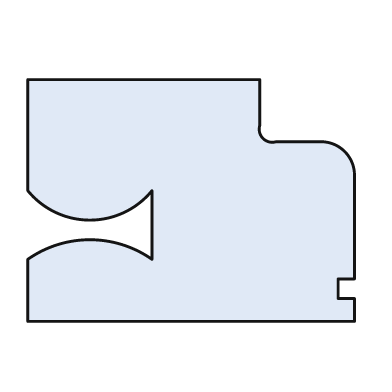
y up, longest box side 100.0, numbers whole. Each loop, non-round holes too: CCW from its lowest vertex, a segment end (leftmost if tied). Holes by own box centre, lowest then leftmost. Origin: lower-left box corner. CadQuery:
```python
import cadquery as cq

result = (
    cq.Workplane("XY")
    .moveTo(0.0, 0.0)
    .lineTo(100.0, 0.0)
    .lineTo(100.0, 7.0)
    .lineTo(95.0, 7.0)
    .lineTo(95.0, 13.0)
    .lineTo(100.0, 13.0)
    .lineTo(100.0, 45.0)
    .threePointArc((97.0, 52.0), (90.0, 55.0))
    .lineTo(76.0, 55.0)
    .threePointArc((72.0, 56.0), (71.0, 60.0))
    .lineTo(71.0, 74.0)
    .lineTo(0.0, 74.0)
    .lineTo(0.0, 40.0)
    .threePointArc((19.0, 31.0), (38.0, 40.0))
    .lineTo(38.0, 19.0)
    .threePointArc((19.0, 25.0), (0.0, 19.0))
    .close()
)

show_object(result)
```